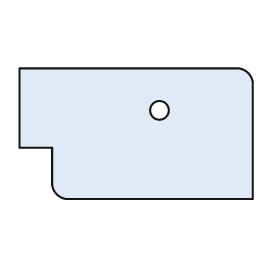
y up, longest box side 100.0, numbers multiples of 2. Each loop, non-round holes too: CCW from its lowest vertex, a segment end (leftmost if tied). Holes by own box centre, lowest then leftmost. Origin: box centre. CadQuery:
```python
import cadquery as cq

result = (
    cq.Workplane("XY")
    .moveTo(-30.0, -28.0)
    .lineTo(50.0, -28.0)
    .lineTo(50.0, 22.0)
    .threePointArc((48.0, 26.0), (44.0, 28.0))
    .lineTo(-50.0, 28.0)
    .lineTo(-50.0, -6.0)
    .lineTo(-36.0, -6.0)
    .lineTo(-36.0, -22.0)
    .threePointArc((-34.0, -26.0), (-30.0, -28.0))
    .close()
    .moveTo(10.0, 10.0)
    .circle(4.0)
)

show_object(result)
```